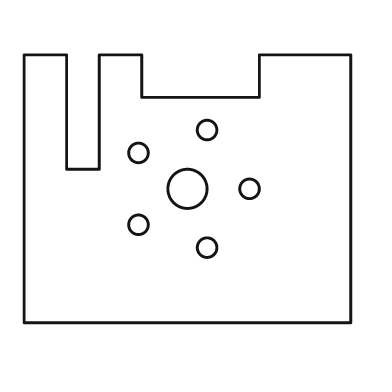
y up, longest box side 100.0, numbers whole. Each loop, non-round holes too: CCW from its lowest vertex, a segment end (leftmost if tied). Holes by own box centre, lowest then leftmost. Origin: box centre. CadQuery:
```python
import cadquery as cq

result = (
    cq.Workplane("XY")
    .moveTo(-50.0, -41.0)
    .lineTo(50.0, -41.0)
    .lineTo(50.0, 41.0)
    .lineTo(22.0, 41.0)
    .lineTo(22.0, 28.0)
    .lineTo(-14.0, 28.0)
    .lineTo(-14.0, 41.0)
    .lineTo(-27.0, 41.0)
    .lineTo(-27.0, 6.0)
    .lineTo(-37.0, 6.0)
    .lineTo(-37.0, 41.0)
    .lineTo(-50.0, 41.0)
    .close()
    .moveTo(6.0, -18.0)
    .circle(3.0)
    .moveTo(-15.0, -11.0)
    .circle(3.0)
    .moveTo(0.0, 0.0)
    .circle(6.0)
    .moveTo(19.0, 0.0)
    .circle(3.0)
    .moveTo(-15.0, 11.0)
    .circle(3.0)
    .moveTo(6.0, 18.0)
    .circle(3.0)
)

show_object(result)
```